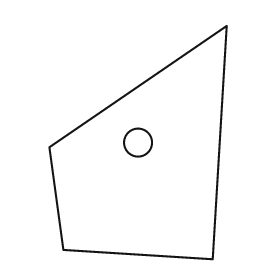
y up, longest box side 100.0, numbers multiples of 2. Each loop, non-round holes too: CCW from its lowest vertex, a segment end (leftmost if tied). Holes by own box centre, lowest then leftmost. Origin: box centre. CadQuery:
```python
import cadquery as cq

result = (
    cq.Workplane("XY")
    .moveTo(32.0, -50.0)
    .lineTo(38.0, 50.0)
    .lineTo(-38.0, -2.0)
    .lineTo(-32.0, -46.0)
    .close()
    .moveTo(0.0, 0.0)
    .circle(6.0)
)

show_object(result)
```